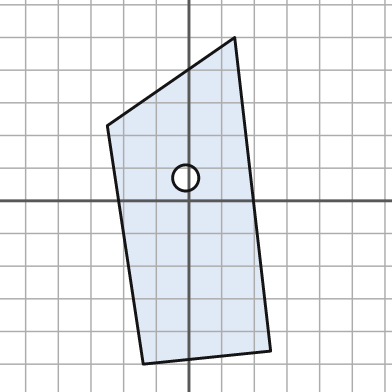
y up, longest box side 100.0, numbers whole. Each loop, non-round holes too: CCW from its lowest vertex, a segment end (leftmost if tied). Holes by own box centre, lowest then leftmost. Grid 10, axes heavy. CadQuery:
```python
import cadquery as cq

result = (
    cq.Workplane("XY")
    .moveTo(-14.0, -50.0)
    .lineTo(25.0, -46.0)
    .lineTo(14.0, 50.0)
    .lineTo(-25.0, 23.0)
    .close()
    .moveTo(-1.0, 7.0)
    .circle(4.0)
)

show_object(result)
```